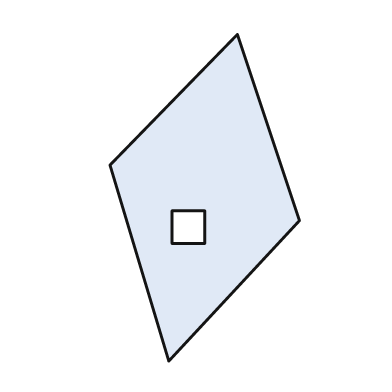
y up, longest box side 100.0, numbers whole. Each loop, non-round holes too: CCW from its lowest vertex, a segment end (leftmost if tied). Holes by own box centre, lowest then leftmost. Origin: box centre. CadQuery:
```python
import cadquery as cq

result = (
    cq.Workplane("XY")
    .moveTo(-11.0, -50.0)
    .lineTo(29.0, -7.0)
    .lineTo(10.0, 50.0)
    .lineTo(-29.0, 10.0)
    .close()
    .moveTo(-10.0, -14.0)
    .lineTo(0.0, -14.0)
    .lineTo(0.0, -4.0)
    .lineTo(-10.0, -4.0)
    .close()
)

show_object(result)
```